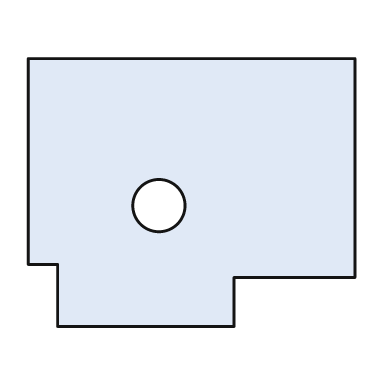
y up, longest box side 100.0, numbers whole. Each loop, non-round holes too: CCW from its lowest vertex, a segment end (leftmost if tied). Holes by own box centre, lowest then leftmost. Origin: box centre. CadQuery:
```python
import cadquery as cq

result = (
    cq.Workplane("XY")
    .moveTo(-41.0, -41.0)
    .lineTo(13.0, -41.0)
    .lineTo(13.0, -26.0)
    .lineTo(50.0, -26.0)
    .lineTo(50.0, 41.0)
    .lineTo(-50.0, 41.0)
    .lineTo(-50.0, -22.0)
    .lineTo(-41.0, -22.0)
    .close()
    .moveTo(-10.0, -4.0)
    .circle(8.0)
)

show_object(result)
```